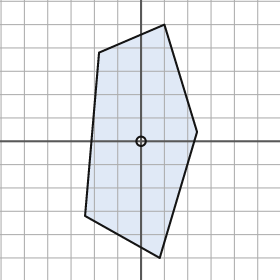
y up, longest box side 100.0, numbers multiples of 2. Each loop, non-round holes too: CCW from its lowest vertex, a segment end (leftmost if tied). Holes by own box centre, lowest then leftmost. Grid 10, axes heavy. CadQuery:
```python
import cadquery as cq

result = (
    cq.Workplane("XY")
    .moveTo(8.0, -50.0)
    .lineTo(24.0, 4.0)
    .lineTo(10.0, 50.0)
    .lineTo(-18.0, 38.0)
    .lineTo(-24.0, -32.0)
    .close()
    .moveTo(0.0, 0.0)
    .circle(2.0)
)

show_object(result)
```